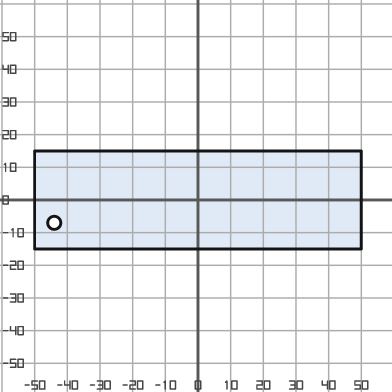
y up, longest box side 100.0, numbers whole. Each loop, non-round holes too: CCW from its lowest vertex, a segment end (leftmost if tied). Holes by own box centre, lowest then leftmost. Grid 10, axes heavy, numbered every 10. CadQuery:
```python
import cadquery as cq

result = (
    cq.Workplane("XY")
    .moveTo(-50.0, -15.0)
    .lineTo(50.0, -15.0)
    .lineTo(50.0, 15.0)
    .lineTo(-50.0, 15.0)
    .close()
    .moveTo(-44.0, -7.0)
    .circle(2.0)
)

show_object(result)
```